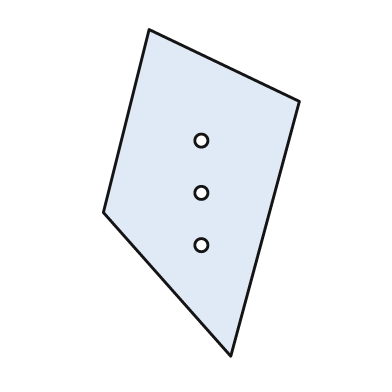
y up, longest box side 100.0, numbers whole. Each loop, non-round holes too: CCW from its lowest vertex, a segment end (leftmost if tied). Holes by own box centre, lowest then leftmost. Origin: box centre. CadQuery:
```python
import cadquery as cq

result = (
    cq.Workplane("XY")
    .moveTo(9.0, -50.0)
    .lineTo(30.0, 28.0)
    .lineTo(-16.0, 50.0)
    .lineTo(-30.0, -6.0)
    .close()
    .moveTo(0.0, -16.0)
    .circle(2.0)
    .moveTo(0.0, 0.0)
    .circle(2.0)
    .moveTo(0.0, 16.0)
    .circle(2.0)
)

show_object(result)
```